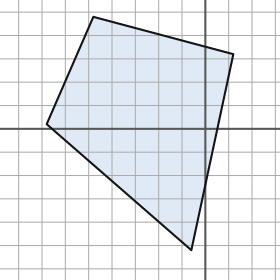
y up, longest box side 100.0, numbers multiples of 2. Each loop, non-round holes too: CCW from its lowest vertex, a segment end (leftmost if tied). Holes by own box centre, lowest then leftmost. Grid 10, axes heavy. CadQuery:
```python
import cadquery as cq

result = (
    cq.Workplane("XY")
    .moveTo(-6.0, -52.0)
    .lineTo(12.0, 32.0)
    .lineTo(-48.0, 48.0)
    .lineTo(-68.0, 2.0)
    .close()
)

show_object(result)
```